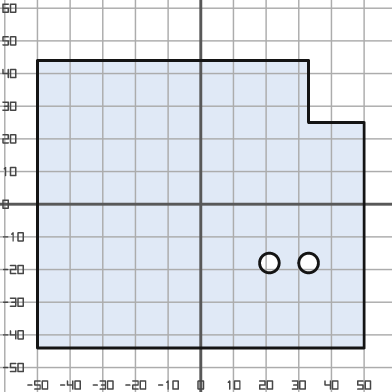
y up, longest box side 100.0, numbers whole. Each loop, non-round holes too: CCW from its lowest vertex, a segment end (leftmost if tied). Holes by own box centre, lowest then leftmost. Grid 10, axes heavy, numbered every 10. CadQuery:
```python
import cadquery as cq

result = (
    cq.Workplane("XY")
    .moveTo(-50.0, -44.0)
    .lineTo(50.0, -44.0)
    .lineTo(50.0, 25.0)
    .lineTo(33.0, 25.0)
    .lineTo(33.0, 44.0)
    .lineTo(-50.0, 44.0)
    .close()
    .moveTo(21.0, -18.0)
    .circle(3.0)
    .moveTo(33.0, -18.0)
    .circle(3.0)
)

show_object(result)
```